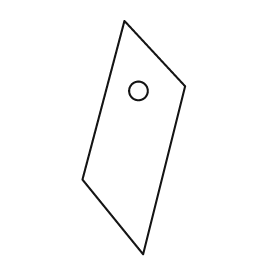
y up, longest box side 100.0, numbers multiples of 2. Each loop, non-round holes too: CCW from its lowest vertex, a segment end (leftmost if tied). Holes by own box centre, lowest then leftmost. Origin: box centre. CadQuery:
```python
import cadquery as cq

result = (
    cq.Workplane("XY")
    .moveTo(4.0, -50.0)
    .lineTo(22.0, 22.0)
    .lineTo(-4.0, 50.0)
    .lineTo(-22.0, -18.0)
    .close()
    .moveTo(2.0, 20.0)
    .circle(4.0)
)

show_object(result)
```